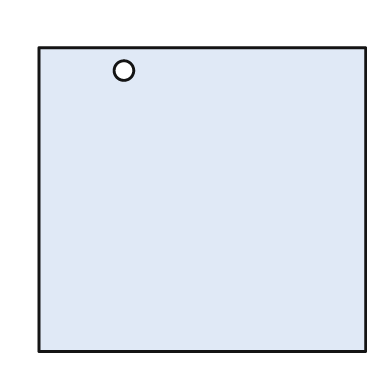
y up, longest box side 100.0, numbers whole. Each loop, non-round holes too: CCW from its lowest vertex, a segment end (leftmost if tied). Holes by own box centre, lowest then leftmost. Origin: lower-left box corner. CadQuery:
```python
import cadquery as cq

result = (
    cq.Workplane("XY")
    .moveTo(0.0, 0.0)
    .lineTo(100.0, 0.0)
    .lineTo(100.0, 93.0)
    .lineTo(0.0, 93.0)
    .close()
    .moveTo(26.0, 86.0)
    .circle(3.0)
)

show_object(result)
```